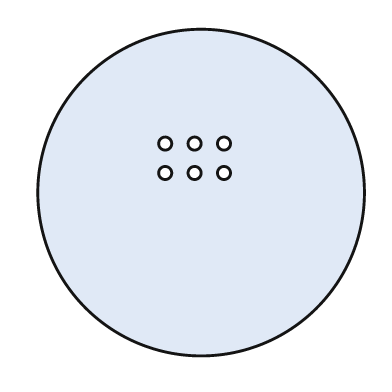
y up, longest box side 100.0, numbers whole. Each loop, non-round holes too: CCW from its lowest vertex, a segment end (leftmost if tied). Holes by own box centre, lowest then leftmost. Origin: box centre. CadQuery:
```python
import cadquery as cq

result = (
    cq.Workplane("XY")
    .moveTo(0.0, 0.0)
    .circle(50.0)
    .moveTo(-11.0, 6.0)
    .circle(2.0)
    .moveTo(-2.0, 6.0)
    .circle(2.0)
    .moveTo(7.0, 6.0)
    .circle(2.0)
    .moveTo(-11.0, 15.0)
    .circle(2.0)
    .moveTo(-2.0, 15.0)
    .circle(2.0)
    .moveTo(7.0, 15.0)
    .circle(2.0)
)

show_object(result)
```